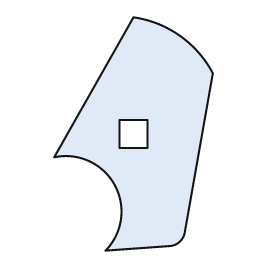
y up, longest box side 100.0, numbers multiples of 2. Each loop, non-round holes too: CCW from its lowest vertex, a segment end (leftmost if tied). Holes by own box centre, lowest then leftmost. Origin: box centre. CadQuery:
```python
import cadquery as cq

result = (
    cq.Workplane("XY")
    .moveTo(-12.0, -50.0)
    .lineTo(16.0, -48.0)
    .threePointArc((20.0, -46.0), (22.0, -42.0))
    .lineTo(34.0, 26.0)
    .threePointArc((20.0, 42.0), (0.0, 50.0))
    .lineTo(-34.0, -10.0)
    .threePointArc((-8.0, -22.0), (-12.0, -50.0))
    .close()
    .moveTo(-6.0, -6.0)
    .lineTo(6.0, -6.0)
    .lineTo(6.0, 6.0)
    .lineTo(-6.0, 6.0)
    .close()
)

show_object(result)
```